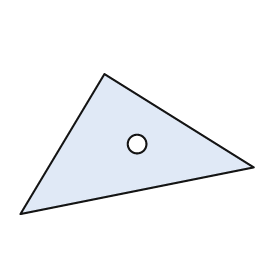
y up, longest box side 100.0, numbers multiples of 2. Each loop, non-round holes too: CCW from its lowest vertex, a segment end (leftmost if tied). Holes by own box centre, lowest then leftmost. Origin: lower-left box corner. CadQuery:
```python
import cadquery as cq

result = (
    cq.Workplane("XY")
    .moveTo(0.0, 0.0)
    .lineTo(100.0, 20.0)
    .lineTo(36.0, 60.0)
    .close()
    .moveTo(50.0, 30.0)
    .circle(4.0)
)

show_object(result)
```